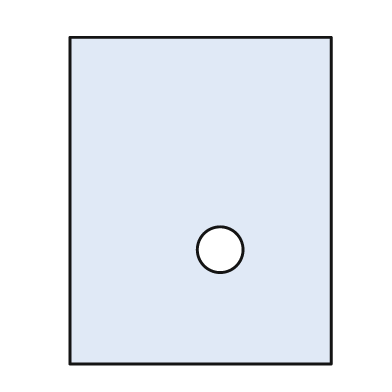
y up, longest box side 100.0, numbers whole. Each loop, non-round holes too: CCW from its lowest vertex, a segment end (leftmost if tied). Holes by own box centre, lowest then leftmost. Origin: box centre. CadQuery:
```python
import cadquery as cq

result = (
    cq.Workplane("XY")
    .moveTo(-40.0, -50.0)
    .lineTo(40.0, -50.0)
    .lineTo(40.0, 50.0)
    .lineTo(-40.0, 50.0)
    .close()
    .moveTo(6.0, -15.0)
    .circle(7.0)
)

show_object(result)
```